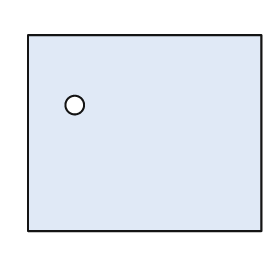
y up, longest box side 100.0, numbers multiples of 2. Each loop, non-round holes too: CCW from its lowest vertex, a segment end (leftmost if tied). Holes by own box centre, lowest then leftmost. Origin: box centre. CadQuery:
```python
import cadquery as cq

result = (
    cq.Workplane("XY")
    .moveTo(-50.0, -42.0)
    .lineTo(50.0, -42.0)
    .lineTo(50.0, 42.0)
    .lineTo(-50.0, 42.0)
    .close()
    .moveTo(-30.0, 12.0)
    .circle(4.0)
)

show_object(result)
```